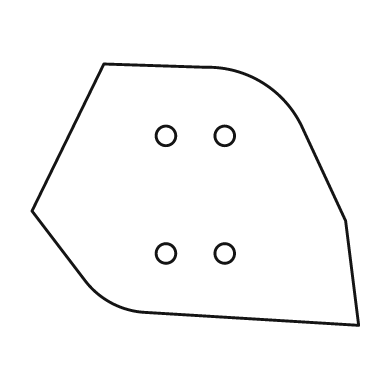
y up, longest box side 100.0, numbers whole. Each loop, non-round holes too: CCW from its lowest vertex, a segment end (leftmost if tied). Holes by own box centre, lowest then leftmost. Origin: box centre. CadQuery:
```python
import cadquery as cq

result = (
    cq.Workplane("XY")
    .moveTo(50.0, -40.0)
    .lineTo(46.0, -8.0)
    .lineTo(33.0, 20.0)
    .threePointArc((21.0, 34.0), (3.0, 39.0))
    .lineTo(-28.0, 40.0)
    .lineTo(-50.0, -5.0)
    .lineTo(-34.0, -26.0)
    .threePointArc((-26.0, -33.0), (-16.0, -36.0))
    .close()
    .moveTo(-9.0, -18.0)
    .circle(3.0)
    .moveTo(9.0, -18.0)
    .circle(3.0)
    .moveTo(-9.0, 18.0)
    .circle(3.0)
    .moveTo(9.0, 18.0)
    .circle(3.0)
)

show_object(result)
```